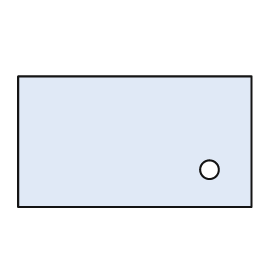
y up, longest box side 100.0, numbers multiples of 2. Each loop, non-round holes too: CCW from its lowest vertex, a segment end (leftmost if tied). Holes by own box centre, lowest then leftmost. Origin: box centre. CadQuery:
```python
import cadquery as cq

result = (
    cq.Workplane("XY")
    .moveTo(-50.0, -28.0)
    .lineTo(50.0, -28.0)
    .lineTo(50.0, 28.0)
    .lineTo(-50.0, 28.0)
    .close()
    .moveTo(32.0, -12.0)
    .circle(4.0)
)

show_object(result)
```